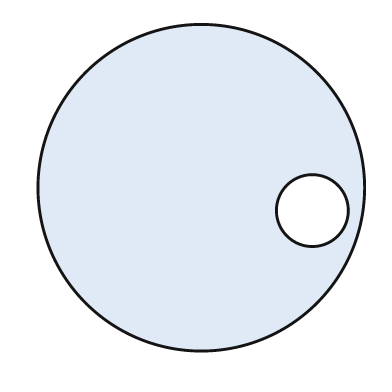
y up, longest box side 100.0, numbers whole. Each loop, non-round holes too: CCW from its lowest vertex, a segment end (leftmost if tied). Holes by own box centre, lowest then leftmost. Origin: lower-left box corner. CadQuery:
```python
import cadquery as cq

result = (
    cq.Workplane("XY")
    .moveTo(50.0, 50.0)
    .circle(50.0)
    .moveTo(84.0, 43.0)
    .circle(11.0)
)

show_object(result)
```